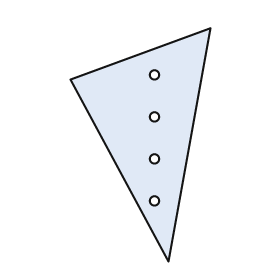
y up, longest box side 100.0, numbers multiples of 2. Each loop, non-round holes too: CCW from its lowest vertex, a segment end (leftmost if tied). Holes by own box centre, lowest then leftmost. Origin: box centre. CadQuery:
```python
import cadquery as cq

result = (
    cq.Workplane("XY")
    .moveTo(12.0, -50.0)
    .lineTo(30.0, 50.0)
    .lineTo(-30.0, 28.0)
    .close()
    .moveTo(6.0, -24.0)
    .circle(2.0)
    .moveTo(6.0, -6.0)
    .circle(2.0)
    .moveTo(6.0, 12.0)
    .circle(2.0)
    .moveTo(6.0, 30.0)
    .circle(2.0)
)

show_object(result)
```